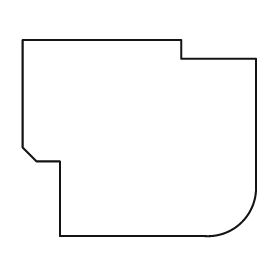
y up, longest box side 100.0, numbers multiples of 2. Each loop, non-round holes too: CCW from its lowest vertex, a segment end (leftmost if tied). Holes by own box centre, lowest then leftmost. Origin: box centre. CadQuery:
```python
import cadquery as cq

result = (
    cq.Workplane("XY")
    .moveTo(-34.0, -42.0)
    .lineTo(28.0, -42.0)
    .threePointArc((44.0, -36.0), (50.0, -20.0))
    .lineTo(50.0, 34.0)
    .lineTo(18.0, 34.0)
    .lineTo(18.0, 42.0)
    .lineTo(-50.0, 42.0)
    .lineTo(-50.0, -4.0)
    .lineTo(-44.0, -10.0)
    .lineTo(-34.0, -10.0)
    .close()
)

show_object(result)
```